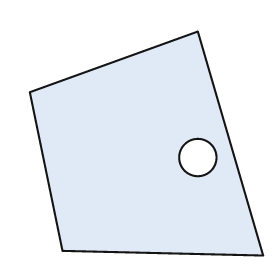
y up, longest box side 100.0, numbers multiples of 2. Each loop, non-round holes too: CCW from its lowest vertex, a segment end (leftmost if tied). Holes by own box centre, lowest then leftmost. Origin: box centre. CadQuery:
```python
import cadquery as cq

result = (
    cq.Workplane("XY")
    .moveTo(50.0, -48.0)
    .lineTo(22.0, 48.0)
    .lineTo(-50.0, 22.0)
    .lineTo(-36.0, -46.0)
    .close()
    .moveTo(22.0, -6.0)
    .circle(8.0)
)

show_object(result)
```